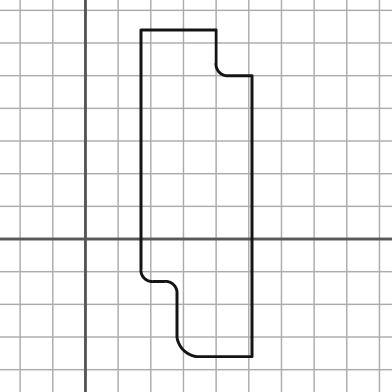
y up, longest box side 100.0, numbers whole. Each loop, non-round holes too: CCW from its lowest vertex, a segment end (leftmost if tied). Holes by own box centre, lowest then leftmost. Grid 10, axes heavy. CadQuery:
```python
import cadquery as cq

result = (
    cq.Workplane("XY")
    .moveTo(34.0, -36.0)
    .lineTo(51.0, -36.0)
    .lineTo(51.0, 50.0)
    .lineTo(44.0, 50.0)
    .threePointArc((41.0, 51.0), (40.0, 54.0))
    .lineTo(40.0, 64.0)
    .lineTo(17.0, 64.0)
    .lineTo(17.0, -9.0)
    .threePointArc((18.0, -12.0), (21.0, -13.0))
    .lineTo(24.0, -13.0)
    .threePointArc((27.0, -14.0), (28.0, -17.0))
    .lineTo(28.0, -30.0)
    .threePointArc((30.0, -34.0), (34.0, -36.0))
    .close()
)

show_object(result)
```